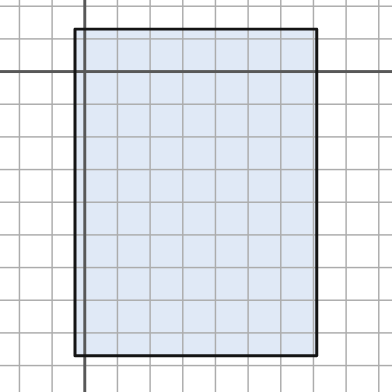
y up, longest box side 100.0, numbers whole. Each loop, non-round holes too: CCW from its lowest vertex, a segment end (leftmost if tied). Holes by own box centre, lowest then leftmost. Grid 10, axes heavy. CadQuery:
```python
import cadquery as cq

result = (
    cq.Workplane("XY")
    .moveTo(-3.0, -87.0)
    .lineTo(71.0, -87.0)
    .lineTo(71.0, 13.0)
    .lineTo(-3.0, 13.0)
    .close()
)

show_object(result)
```